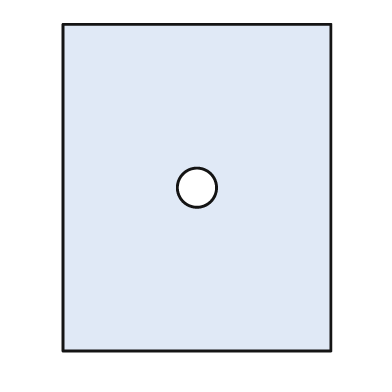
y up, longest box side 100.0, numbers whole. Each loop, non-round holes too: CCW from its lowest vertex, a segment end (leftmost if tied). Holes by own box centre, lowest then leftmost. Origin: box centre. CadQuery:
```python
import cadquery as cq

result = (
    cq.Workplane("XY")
    .moveTo(-41.0, -50.0)
    .lineTo(41.0, -50.0)
    .lineTo(41.0, 50.0)
    .lineTo(-41.0, 50.0)
    .close()
    .moveTo(0.0, 0.0)
    .circle(6.0)
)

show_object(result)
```